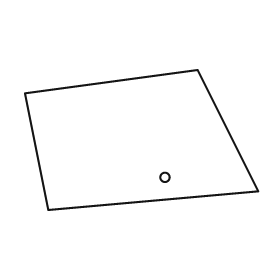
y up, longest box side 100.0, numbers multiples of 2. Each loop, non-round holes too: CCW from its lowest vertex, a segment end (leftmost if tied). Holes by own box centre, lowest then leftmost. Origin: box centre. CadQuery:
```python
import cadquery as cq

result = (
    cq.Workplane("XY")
    .moveTo(-40.0, -30.0)
    .lineTo(50.0, -22.0)
    .lineTo(24.0, 30.0)
    .lineTo(-50.0, 20.0)
    .close()
    .moveTo(10.0, -16.0)
    .circle(2.0)
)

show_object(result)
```